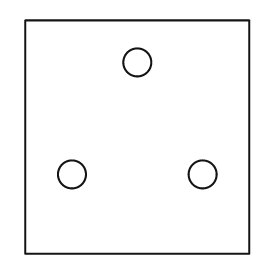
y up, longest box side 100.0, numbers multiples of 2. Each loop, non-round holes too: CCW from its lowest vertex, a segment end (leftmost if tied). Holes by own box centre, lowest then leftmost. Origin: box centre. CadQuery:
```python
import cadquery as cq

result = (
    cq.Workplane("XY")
    .moveTo(-48.0, -50.0)
    .lineTo(48.0, -50.0)
    .lineTo(48.0, 50.0)
    .lineTo(-48.0, 50.0)
    .close()
    .moveTo(-28.0, -16.0)
    .circle(6.0)
    .moveTo(28.0, -16.0)
    .circle(6.0)
    .moveTo(0.0, 32.0)
    .circle(6.0)
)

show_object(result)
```